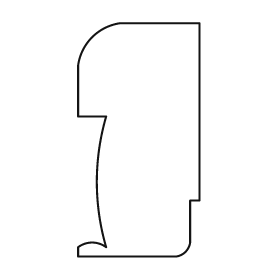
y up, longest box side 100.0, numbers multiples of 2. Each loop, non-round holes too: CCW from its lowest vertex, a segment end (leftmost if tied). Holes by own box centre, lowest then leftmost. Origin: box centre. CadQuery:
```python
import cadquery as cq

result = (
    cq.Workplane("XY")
    .moveTo(-26.0, -50.0)
    .lineTo(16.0, -50.0)
    .threePointArc((20.0, -48.0), (22.0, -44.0))
    .lineTo(22.0, -26.0)
    .lineTo(26.0, -26.0)
    .lineTo(26.0, 50.0)
    .lineTo(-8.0, 50.0)
    .threePointArc((-20.0, 44.0), (-26.0, 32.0))
    .lineTo(-26.0, 10.0)
    .lineTo(-14.0, 10.0)
    .threePointArc((-18.0, -18.0), (-14.0, -46.0))
    .threePointArc((-20.0, -44.0), (-26.0, -46.0))
    .close()
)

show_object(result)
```